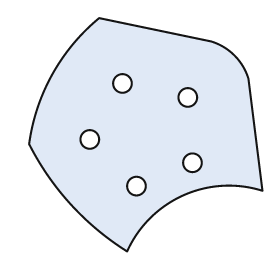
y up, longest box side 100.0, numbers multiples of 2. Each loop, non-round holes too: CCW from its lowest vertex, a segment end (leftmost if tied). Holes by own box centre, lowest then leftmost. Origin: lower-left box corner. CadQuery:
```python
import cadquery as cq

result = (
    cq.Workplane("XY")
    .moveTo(42.0, 0.0)
    .threePointArc((66.0, 24.0), (100.0, 26.0))
    .lineTo(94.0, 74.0)
    .threePointArc((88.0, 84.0), (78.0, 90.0))
    .lineTo(30.0, 100.0)
    .threePointArc((10.0, 76.0), (0.0, 46.0))
    .threePointArc((18.0, 20.0), (42.0, 0.0))
    .close()
    .moveTo(46.0, 28.0)
    .circle(4.0)
    .moveTo(70.0, 38.0)
    .circle(4.0)
    .moveTo(26.0, 48.0)
    .circle(4.0)
    .moveTo(68.0, 66.0)
    .circle(4.0)
    .moveTo(40.0, 72.0)
    .circle(4.0)
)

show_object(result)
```